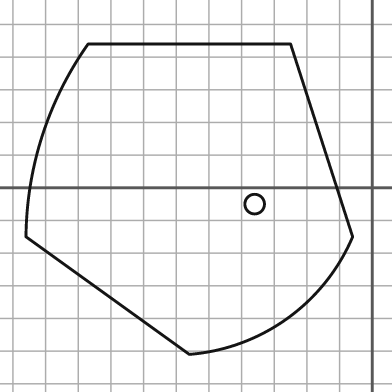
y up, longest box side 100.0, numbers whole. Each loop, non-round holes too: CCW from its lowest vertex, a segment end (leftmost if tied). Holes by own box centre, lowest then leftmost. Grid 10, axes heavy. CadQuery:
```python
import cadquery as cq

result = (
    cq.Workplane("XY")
    .moveTo(-56.0, -51.0)
    .threePointArc((-26.0, -40.0), (-6.0, -15.0))
    .lineTo(-25.0, 44.0)
    .lineTo(-87.0, 44.0)
    .threePointArc((-101.0, 16.0), (-106.0, -15.0))
    .close()
    .moveTo(-36.0, -5.0)
    .circle(3.0)
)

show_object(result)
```